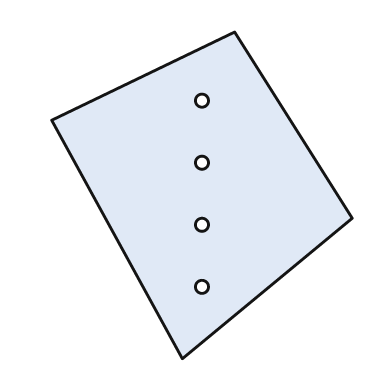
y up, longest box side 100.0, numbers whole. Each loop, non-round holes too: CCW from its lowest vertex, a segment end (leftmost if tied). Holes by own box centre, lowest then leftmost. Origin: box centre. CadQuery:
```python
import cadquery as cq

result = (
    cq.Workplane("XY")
    .moveTo(-6.0, -50.0)
    .lineTo(46.0, -7.0)
    .lineTo(10.0, 50.0)
    .lineTo(-46.0, 23.0)
    .close()
    .moveTo(0.0, -28.0)
    .circle(2.0)
    .moveTo(0.0, -9.0)
    .circle(2.0)
    .moveTo(0.0, 10.0)
    .circle(2.0)
    .moveTo(0.0, 29.0)
    .circle(2.0)
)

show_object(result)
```